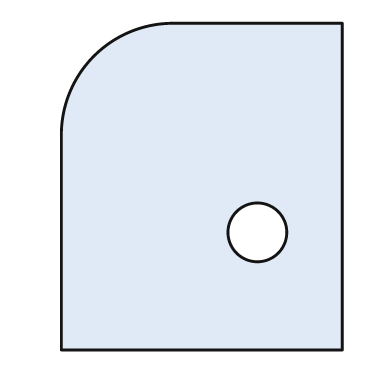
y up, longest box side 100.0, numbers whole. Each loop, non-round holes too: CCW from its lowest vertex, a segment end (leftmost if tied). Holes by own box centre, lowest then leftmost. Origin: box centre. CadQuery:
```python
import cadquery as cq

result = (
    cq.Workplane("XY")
    .moveTo(-43.0, -50.0)
    .lineTo(43.0, -50.0)
    .lineTo(43.0, 50.0)
    .lineTo(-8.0, 50.0)
    .threePointArc((-33.0, 40.0), (-43.0, 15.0))
    .close()
    .moveTo(17.0, -14.0)
    .circle(9.0)
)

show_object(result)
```